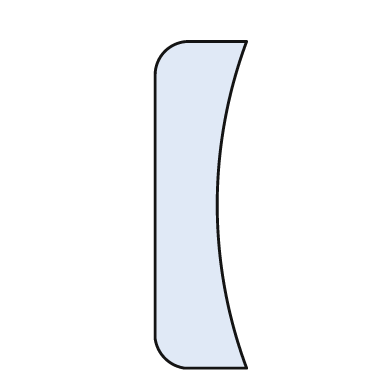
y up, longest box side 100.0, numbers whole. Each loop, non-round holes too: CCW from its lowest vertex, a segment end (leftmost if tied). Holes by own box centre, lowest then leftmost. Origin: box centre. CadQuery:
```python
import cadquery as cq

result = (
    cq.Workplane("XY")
    .moveTo(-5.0, -50.0)
    .lineTo(14.0, -50.0)
    .threePointArc((5.0, 0.0), (14.0, 50.0))
    .lineTo(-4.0, 50.0)
    .threePointArc((-11.0, 47.0), (-14.0, 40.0))
    .lineTo(-14.0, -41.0)
    .threePointArc((-11.0, -47.0), (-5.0, -50.0))
    .close()
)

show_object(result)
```